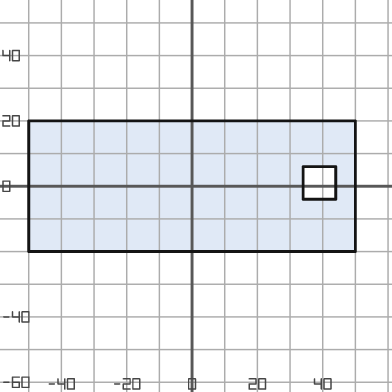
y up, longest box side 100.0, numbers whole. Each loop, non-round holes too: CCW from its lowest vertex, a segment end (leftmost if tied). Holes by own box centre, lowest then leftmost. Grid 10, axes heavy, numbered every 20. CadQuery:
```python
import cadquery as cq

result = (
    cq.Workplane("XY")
    .moveTo(-50.0, -20.0)
    .lineTo(50.0, -20.0)
    .lineTo(50.0, 20.0)
    .lineTo(-50.0, 20.0)
    .close()
    .moveTo(34.0, -4.0)
    .lineTo(44.0, -4.0)
    .lineTo(44.0, 6.0)
    .lineTo(34.0, 6.0)
    .close()
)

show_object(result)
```